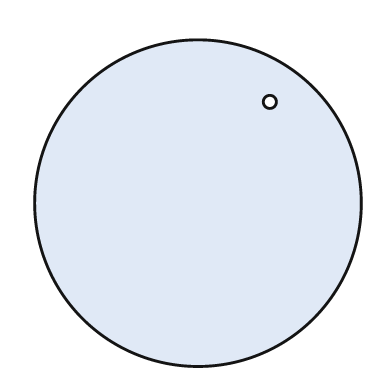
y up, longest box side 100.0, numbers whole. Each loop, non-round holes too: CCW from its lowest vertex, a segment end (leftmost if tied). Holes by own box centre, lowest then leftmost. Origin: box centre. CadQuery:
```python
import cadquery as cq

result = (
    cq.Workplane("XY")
    .moveTo(0.0, 0.0)
    .circle(50.0)
    .moveTo(22.0, 31.0)
    .circle(2.0)
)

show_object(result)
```